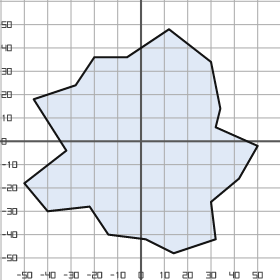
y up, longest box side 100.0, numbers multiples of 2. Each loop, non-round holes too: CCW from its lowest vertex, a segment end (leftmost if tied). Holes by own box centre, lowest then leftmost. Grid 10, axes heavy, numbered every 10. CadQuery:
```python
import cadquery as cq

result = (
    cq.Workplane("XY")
    .moveTo(14.0, -48.0)
    .lineTo(32.0, -42.0)
    .lineTo(30.0, -26.0)
    .lineTo(42.0, -16.0)
    .lineTo(50.0, -2.0)
    .lineTo(32.0, 6.0)
    .lineTo(34.0, 14.0)
    .lineTo(30.0, 34.0)
    .lineTo(12.0, 48.0)
    .lineTo(-6.0, 36.0)
    .lineTo(-20.0, 36.0)
    .lineTo(-28.0, 24.0)
    .lineTo(-46.0, 18.0)
    .lineTo(-32.0, -4.0)
    .lineTo(-50.0, -18.0)
    .lineTo(-40.0, -30.0)
    .lineTo(-22.0, -28.0)
    .lineTo(-14.0, -40.0)
    .lineTo(2.0, -42.0)
    .close()
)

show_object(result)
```